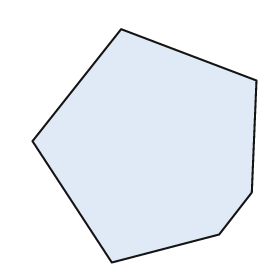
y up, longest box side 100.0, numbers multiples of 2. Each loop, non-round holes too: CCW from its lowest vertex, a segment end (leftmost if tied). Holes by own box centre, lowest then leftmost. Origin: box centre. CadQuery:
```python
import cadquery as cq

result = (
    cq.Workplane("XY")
    .moveTo(-14.0, -50.0)
    .lineTo(32.0, -38.0)
    .lineTo(46.0, -20.0)
    .lineTo(48.0, 28.0)
    .lineTo(-10.0, 50.0)
    .lineTo(-48.0, 2.0)
    .close()
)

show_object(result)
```